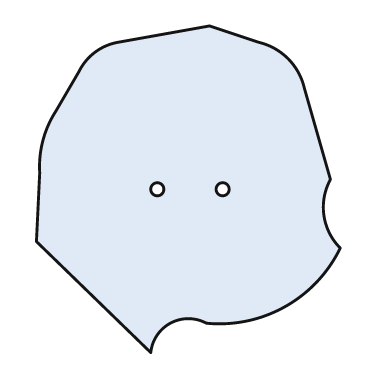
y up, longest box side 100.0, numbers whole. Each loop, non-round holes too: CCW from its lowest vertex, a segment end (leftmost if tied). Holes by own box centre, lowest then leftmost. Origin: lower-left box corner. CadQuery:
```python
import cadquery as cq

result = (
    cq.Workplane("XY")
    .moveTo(35.0, 0.0)
    .threePointArc((41.0, 9.0), (52.0, 9.0))
    .threePointArc((76.0, 14.0), (93.0, 32.0))
    .threePointArc((88.0, 42.0), (90.0, 53.0))
    .lineTo(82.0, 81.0)
    .threePointArc((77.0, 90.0), (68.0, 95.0))
    .lineTo(53.0, 100.0)
    .lineTo(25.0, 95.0)
    .threePointArc((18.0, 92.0), (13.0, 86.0))
    .lineTo(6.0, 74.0)
    .threePointArc((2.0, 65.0), (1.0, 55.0))
    .lineTo(0.0, 34.0)
    .close()
    .moveTo(37.0, 50.0)
    .circle(2.0)
    .moveTo(57.0, 50.0)
    .circle(2.0)
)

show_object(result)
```